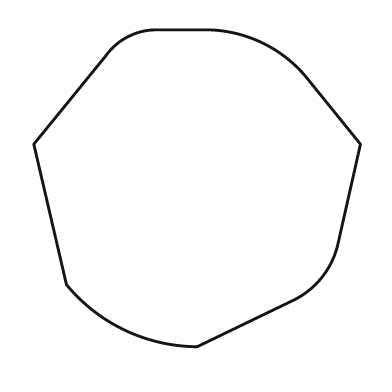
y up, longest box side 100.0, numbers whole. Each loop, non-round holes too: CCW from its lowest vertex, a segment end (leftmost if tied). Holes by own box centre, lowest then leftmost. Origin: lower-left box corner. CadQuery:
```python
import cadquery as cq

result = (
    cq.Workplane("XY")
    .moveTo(50.0, 0.0)
    .lineTo(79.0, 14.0)
    .threePointArc((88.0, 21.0), (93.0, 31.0))
    .lineTo(100.0, 62.0)
    .lineTo(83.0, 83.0)
    .threePointArc((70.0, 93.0), (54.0, 97.0))
    .lineTo(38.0, 97.0)
    .threePointArc((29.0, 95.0), (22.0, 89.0))
    .lineTo(0.0, 62.0)
    .lineTo(10.0, 19.0)
    .threePointArc((28.0, 5.0), (50.0, 0.0))
    .close()
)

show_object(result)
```